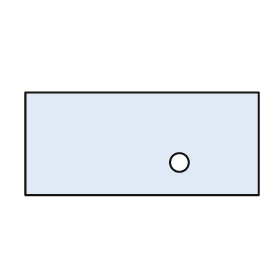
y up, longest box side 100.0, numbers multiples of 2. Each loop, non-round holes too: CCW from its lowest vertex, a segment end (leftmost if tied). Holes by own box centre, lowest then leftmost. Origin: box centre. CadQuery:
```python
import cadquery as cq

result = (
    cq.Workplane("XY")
    .moveTo(-50.0, -22.0)
    .lineTo(50.0, -22.0)
    .lineTo(50.0, 22.0)
    .lineTo(-50.0, 22.0)
    .close()
    .moveTo(16.0, -8.0)
    .circle(4.0)
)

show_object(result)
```